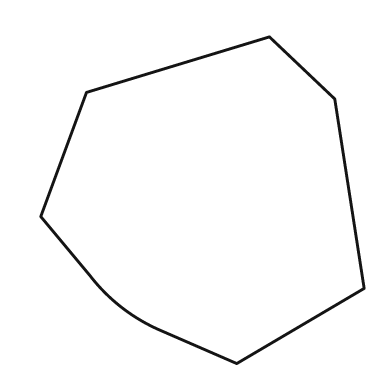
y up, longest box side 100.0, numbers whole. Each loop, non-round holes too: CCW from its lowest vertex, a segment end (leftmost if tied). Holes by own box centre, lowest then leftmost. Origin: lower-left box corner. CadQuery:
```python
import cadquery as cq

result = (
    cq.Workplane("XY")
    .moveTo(60.0, 0.0)
    .lineTo(99.0, 23.0)
    .lineTo(90.0, 81.0)
    .lineTo(70.0, 100.0)
    .lineTo(14.0, 83.0)
    .lineTo(0.0, 45.0)
    .lineTo(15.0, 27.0)
    .threePointArc((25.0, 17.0), (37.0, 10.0))
    .close()
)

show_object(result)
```